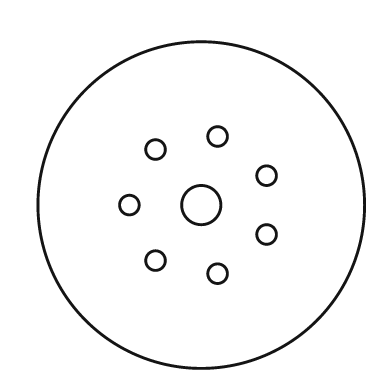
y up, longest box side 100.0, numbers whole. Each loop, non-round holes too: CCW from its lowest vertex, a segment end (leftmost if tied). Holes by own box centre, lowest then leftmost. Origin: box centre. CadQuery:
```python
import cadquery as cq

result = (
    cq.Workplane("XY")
    .moveTo(0.0, 0.0)
    .circle(50.0)
    .moveTo(5.0, -21.0)
    .circle(3.0)
    .moveTo(-14.0, -17.0)
    .circle(3.0)
    .moveTo(20.0, -9.0)
    .circle(3.0)
    .moveTo(-22.0, 0.0)
    .circle(3.0)
    .moveTo(0.0, 0.0)
    .circle(6.0)
    .moveTo(20.0, 9.0)
    .circle(3.0)
    .moveTo(-14.0, 17.0)
    .circle(3.0)
    .moveTo(5.0, 21.0)
    .circle(3.0)
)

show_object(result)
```